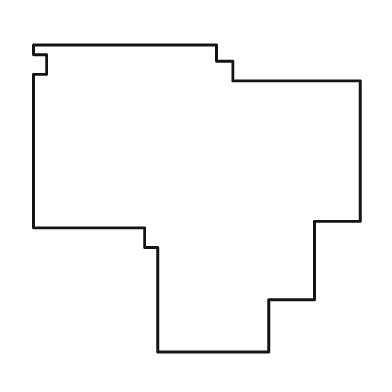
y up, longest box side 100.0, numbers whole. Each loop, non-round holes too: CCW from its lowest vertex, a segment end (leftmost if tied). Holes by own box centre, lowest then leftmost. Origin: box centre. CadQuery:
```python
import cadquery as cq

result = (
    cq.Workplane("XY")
    .moveTo(-12.0, -47.0)
    .lineTo(22.0, -47.0)
    .lineTo(22.0, -31.0)
    .lineTo(36.0, -31.0)
    .lineTo(36.0, -7.0)
    .lineTo(50.0, -7.0)
    .lineTo(50.0, 36.0)
    .lineTo(11.0, 36.0)
    .lineTo(11.0, 42.0)
    .lineTo(6.0, 42.0)
    .lineTo(6.0, 47.0)
    .lineTo(-50.0, 47.0)
    .lineTo(-50.0, 44.0)
    .lineTo(-46.0, 44.0)
    .lineTo(-46.0, 38.0)
    .lineTo(-50.0, 38.0)
    .lineTo(-50.0, -9.0)
    .lineTo(-16.0, -9.0)
    .lineTo(-16.0, -15.0)
    .lineTo(-12.0, -15.0)
    .close()
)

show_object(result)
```